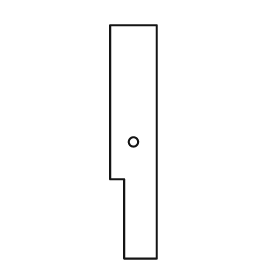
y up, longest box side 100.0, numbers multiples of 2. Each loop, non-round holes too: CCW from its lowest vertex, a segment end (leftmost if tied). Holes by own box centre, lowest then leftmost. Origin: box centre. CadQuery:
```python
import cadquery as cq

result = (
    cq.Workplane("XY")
    .moveTo(-4.0, -50.0)
    .lineTo(10.0, -50.0)
    .lineTo(10.0, 50.0)
    .lineTo(-10.0, 50.0)
    .lineTo(-10.0, -16.0)
    .lineTo(-4.0, -16.0)
    .close()
    .moveTo(0.0, 0.0)
    .circle(2.0)
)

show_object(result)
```